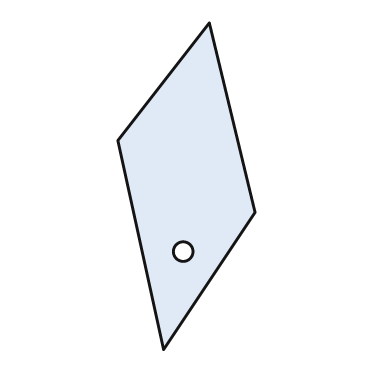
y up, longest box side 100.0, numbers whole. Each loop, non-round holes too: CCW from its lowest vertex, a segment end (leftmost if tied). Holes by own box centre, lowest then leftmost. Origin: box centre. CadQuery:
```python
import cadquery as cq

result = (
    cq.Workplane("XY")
    .moveTo(-7.0, -50.0)
    .lineTo(21.0, -8.0)
    .lineTo(7.0, 50.0)
    .lineTo(-21.0, 14.0)
    .close()
    .moveTo(-1.0, -20.0)
    .circle(3.0)
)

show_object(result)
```